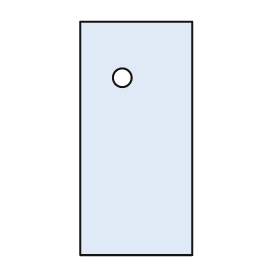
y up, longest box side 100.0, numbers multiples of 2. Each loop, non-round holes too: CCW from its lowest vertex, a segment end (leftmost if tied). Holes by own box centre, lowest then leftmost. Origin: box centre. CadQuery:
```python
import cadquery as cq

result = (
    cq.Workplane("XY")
    .moveTo(-24.0, -50.0)
    .lineTo(24.0, -50.0)
    .lineTo(24.0, 50.0)
    .lineTo(-24.0, 50.0)
    .close()
    .moveTo(-6.0, 26.0)
    .circle(4.0)
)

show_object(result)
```